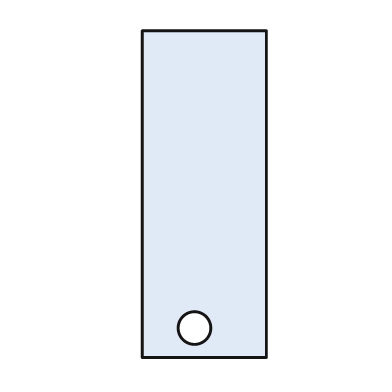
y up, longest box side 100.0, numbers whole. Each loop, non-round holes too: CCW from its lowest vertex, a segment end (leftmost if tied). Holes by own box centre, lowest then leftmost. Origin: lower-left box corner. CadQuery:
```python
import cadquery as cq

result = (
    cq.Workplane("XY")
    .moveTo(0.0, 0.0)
    .lineTo(38.0, 0.0)
    .lineTo(38.0, 100.0)
    .lineTo(0.0, 100.0)
    .close()
    .moveTo(16.0, 9.0)
    .circle(5.0)
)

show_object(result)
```